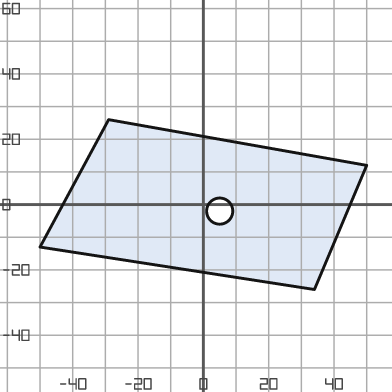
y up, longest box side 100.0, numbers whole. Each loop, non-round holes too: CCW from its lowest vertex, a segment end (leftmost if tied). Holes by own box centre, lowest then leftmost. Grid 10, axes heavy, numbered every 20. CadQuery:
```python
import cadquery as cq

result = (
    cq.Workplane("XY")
    .moveTo(34.0, -26.0)
    .lineTo(50.0, 12.0)
    .lineTo(-29.0, 26.0)
    .lineTo(-50.0, -13.0)
    .close()
    .moveTo(5.0, -2.0)
    .circle(4.0)
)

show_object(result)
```